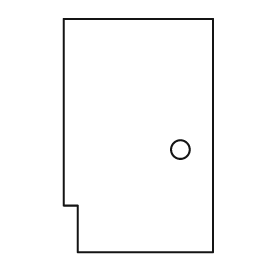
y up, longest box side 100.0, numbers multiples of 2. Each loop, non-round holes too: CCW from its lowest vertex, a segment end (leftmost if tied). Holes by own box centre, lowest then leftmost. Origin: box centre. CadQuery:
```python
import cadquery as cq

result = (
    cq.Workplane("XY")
    .moveTo(-26.0, -50.0)
    .lineTo(32.0, -50.0)
    .lineTo(32.0, 50.0)
    .lineTo(-32.0, 50.0)
    .lineTo(-32.0, -30.0)
    .lineTo(-26.0, -30.0)
    .close()
    .moveTo(18.0, -6.0)
    .circle(4.0)
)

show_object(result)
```